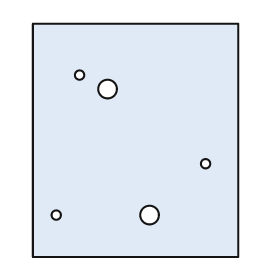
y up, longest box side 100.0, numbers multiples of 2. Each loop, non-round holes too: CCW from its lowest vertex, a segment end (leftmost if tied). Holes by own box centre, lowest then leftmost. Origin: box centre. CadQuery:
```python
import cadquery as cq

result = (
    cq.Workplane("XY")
    .moveTo(-44.0, -50.0)
    .lineTo(44.0, -50.0)
    .lineTo(44.0, 50.0)
    .lineTo(-44.0, 50.0)
    .close()
    .moveTo(-34.0, -32.0)
    .circle(2.0)
    .moveTo(6.0, -32.0)
    .circle(4.0)
    .moveTo(30.0, -10.0)
    .circle(2.0)
    .moveTo(-12.0, 22.0)
    .circle(4.0)
    .moveTo(-24.0, 28.0)
    .circle(2.0)
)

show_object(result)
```